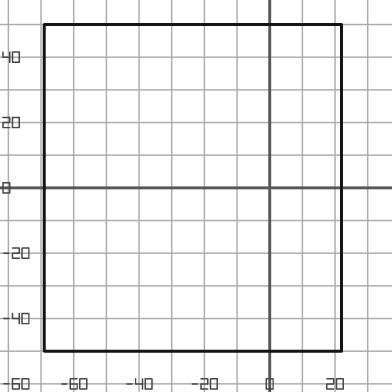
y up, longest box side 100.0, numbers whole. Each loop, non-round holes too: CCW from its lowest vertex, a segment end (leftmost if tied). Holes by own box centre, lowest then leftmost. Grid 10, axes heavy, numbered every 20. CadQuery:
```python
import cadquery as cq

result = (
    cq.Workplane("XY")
    .moveTo(-69.0, -50.0)
    .lineTo(22.0, -50.0)
    .lineTo(22.0, 50.0)
    .lineTo(-69.0, 50.0)
    .close()
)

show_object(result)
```